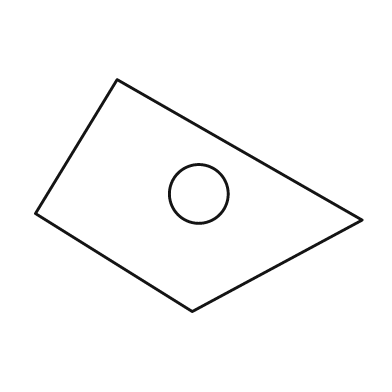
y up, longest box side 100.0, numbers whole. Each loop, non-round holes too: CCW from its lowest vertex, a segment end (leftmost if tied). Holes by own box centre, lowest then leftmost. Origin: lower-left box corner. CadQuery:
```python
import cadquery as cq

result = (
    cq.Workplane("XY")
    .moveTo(48.0, 0.0)
    .lineTo(100.0, 28.0)
    .lineTo(25.0, 71.0)
    .lineTo(0.0, 30.0)
    .close()
    .moveTo(50.0, 36.0)
    .circle(9.0)
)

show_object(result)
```